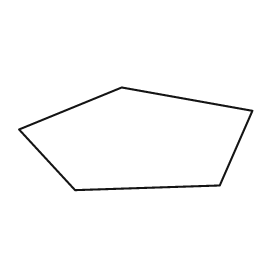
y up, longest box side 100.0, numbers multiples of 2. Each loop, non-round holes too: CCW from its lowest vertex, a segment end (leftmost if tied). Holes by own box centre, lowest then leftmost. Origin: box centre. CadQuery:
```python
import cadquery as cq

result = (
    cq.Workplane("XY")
    .moveTo(-26.0, -22.0)
    .lineTo(36.0, -20.0)
    .lineTo(50.0, 12.0)
    .lineTo(-6.0, 22.0)
    .lineTo(-50.0, 4.0)
    .close()
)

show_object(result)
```